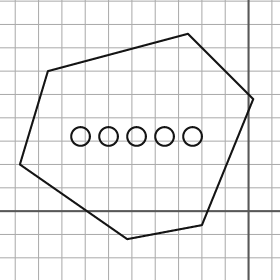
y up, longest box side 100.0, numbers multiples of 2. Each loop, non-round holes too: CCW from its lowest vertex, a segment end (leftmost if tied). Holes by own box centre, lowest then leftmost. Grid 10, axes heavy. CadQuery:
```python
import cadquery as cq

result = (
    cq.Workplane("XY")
    .moveTo(-52.0, -12.0)
    .lineTo(-20.0, -6.0)
    .lineTo(2.0, 48.0)
    .lineTo(-26.0, 76.0)
    .lineTo(-86.0, 60.0)
    .lineTo(-98.0, 20.0)
    .close()
    .moveTo(-72.0, 32.0)
    .circle(4.0)
    .moveTo(-60.0, 32.0)
    .circle(4.0)
    .moveTo(-48.0, 32.0)
    .circle(4.0)
    .moveTo(-36.0, 32.0)
    .circle(4.0)
    .moveTo(-24.0, 32.0)
    .circle(4.0)
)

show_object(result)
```